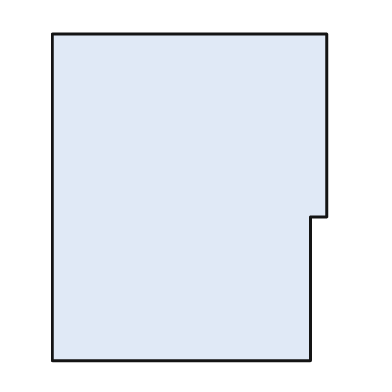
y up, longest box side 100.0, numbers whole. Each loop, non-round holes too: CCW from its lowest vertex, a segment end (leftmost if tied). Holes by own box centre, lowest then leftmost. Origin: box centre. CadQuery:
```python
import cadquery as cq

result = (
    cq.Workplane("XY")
    .moveTo(-42.0, -50.0)
    .lineTo(37.0, -50.0)
    .lineTo(37.0, -6.0)
    .lineTo(42.0, -6.0)
    .lineTo(42.0, 50.0)
    .lineTo(-42.0, 50.0)
    .close()
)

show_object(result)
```